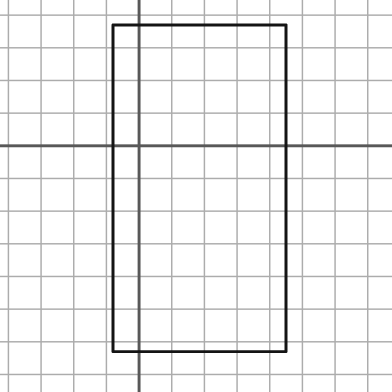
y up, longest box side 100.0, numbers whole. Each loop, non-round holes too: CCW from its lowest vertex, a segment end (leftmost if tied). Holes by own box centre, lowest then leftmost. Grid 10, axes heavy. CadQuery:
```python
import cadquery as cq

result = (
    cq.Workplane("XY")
    .moveTo(-8.0, -63.0)
    .lineTo(45.0, -63.0)
    .lineTo(45.0, 37.0)
    .lineTo(-8.0, 37.0)
    .close()
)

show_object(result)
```